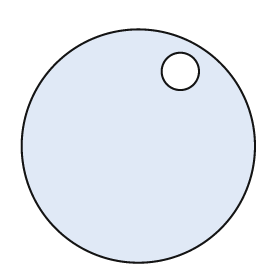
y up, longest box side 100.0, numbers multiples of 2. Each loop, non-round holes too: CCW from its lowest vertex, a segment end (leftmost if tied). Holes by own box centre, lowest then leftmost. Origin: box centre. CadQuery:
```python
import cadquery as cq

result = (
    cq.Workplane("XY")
    .moveTo(0.0, 0.0)
    .circle(50.0)
    .moveTo(18.0, 32.0)
    .circle(8.0)
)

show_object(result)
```